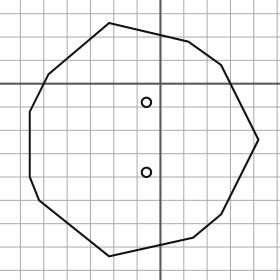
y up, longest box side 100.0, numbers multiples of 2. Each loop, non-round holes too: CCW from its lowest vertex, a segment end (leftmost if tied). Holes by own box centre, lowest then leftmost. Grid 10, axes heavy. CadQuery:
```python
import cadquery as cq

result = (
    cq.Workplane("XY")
    .moveTo(-22.0, -74.0)
    .lineTo(14.0, -66.0)
    .lineTo(26.0, -56.0)
    .lineTo(42.0, -24.0)
    .lineTo(26.0, 8.0)
    .lineTo(12.0, 18.0)
    .lineTo(-22.0, 26.0)
    .lineTo(-48.0, 4.0)
    .lineTo(-56.0, -12.0)
    .lineTo(-56.0, -40.0)
    .lineTo(-52.0, -50.0)
    .close()
    .moveTo(-6.0, -38.0)
    .circle(2.0)
    .moveTo(-6.0, -8.0)
    .circle(2.0)
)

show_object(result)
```